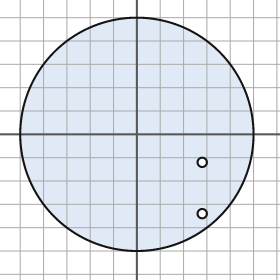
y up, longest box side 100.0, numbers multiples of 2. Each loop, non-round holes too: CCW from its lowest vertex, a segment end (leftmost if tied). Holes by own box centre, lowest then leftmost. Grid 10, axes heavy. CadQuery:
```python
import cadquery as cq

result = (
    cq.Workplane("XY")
    .moveTo(0.0, 0.0)
    .circle(50.0)
    .moveTo(28.0, -34.0)
    .circle(2.0)
    .moveTo(28.0, -12.0)
    .circle(2.0)
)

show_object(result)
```